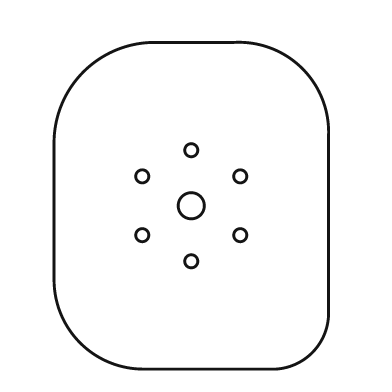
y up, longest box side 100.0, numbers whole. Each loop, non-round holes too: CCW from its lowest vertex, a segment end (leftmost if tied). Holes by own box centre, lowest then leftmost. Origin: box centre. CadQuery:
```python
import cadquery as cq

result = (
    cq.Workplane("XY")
    .moveTo(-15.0, -50.0)
    .lineTo(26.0, -50.0)
    .threePointArc((37.0, -45.0), (42.0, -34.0))
    .lineTo(42.0, 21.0)
    .threePointArc((34.0, 42.0), (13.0, 50.0))
    .lineTo(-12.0, 50.0)
    .threePointArc((-33.0, 41.0), (-42.0, 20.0))
    .lineTo(-42.0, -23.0)
    .threePointArc((-34.0, -42.0), (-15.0, -50.0))
    .close()
    .moveTo(0.0, -17.0)
    .circle(2.0)
    .moveTo(-15.0, -9.0)
    .circle(2.0)
    .moveTo(15.0, -9.0)
    .circle(2.0)
    .moveTo(0.0, 0.0)
    .circle(4.0)
    .moveTo(-15.0, 9.0)
    .circle(2.0)
    .moveTo(15.0, 9.0)
    .circle(2.0)
    .moveTo(0.0, 17.0)
    .circle(2.0)
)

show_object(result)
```